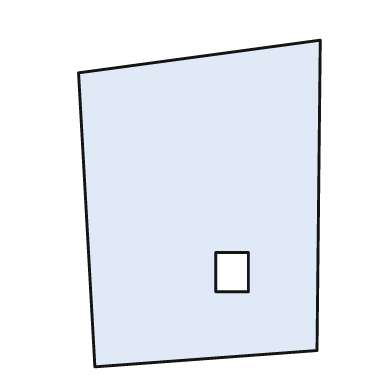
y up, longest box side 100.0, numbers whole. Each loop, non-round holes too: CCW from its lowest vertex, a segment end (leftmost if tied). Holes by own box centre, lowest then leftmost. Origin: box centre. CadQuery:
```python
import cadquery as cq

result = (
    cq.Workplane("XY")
    .moveTo(-32.0, -50.0)
    .lineTo(36.0, -45.0)
    .lineTo(37.0, 50.0)
    .lineTo(-37.0, 40.0)
    .close()
    .moveTo(5.0, -27.0)
    .lineTo(15.0, -27.0)
    .lineTo(15.0, -15.0)
    .lineTo(5.0, -15.0)
    .close()
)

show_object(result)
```